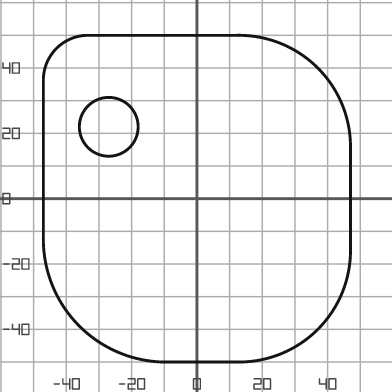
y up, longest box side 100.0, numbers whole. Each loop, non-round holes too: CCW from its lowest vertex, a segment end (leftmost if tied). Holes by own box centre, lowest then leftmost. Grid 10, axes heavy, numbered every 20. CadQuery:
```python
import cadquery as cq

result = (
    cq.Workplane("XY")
    .moveTo(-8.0, -50.0)
    .lineTo(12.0, -50.0)
    .threePointArc((37.0, -40.0), (47.0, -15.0))
    .lineTo(47.0, 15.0)
    .threePointArc((37.0, 40.0), (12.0, 50.0))
    .lineTo(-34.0, 50.0)
    .threePointArc((-43.0, 46.0), (-47.0, 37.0))
    .lineTo(-47.0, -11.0)
    .threePointArc((-36.0, -39.0), (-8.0, -50.0))
    .close()
    .moveTo(-27.0, 22.0)
    .circle(9.0)
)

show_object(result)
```